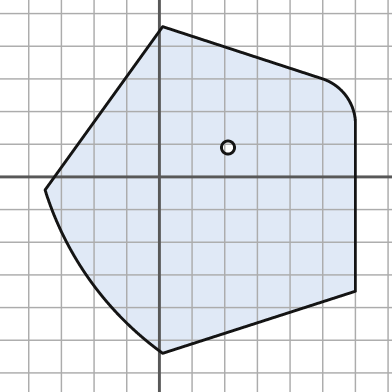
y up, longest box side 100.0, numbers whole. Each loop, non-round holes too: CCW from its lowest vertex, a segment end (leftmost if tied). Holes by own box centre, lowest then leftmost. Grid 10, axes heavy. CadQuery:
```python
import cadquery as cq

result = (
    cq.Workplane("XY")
    .moveTo(1.0, -54.0)
    .lineTo(60.0, -35.0)
    .lineTo(60.0, 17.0)
    .threePointArc((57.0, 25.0), (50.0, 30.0))
    .lineTo(1.0, 46.0)
    .lineTo(-35.0, -4.0)
    .threePointArc((-21.0, -32.0), (1.0, -54.0))
    .close()
    .moveTo(21.0, 9.0)
    .circle(2.0)
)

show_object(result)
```